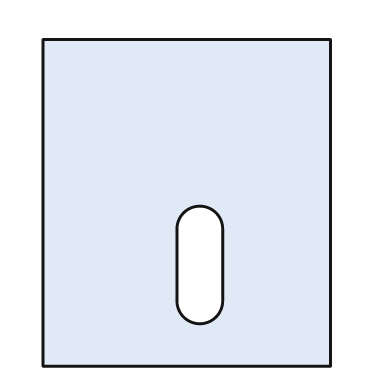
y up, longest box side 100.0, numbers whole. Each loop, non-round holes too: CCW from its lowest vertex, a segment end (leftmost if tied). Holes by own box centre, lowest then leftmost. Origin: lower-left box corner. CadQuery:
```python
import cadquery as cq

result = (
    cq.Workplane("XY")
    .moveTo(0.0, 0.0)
    .lineTo(88.0, 0.0)
    .lineTo(88.0, 100.0)
    .lineTo(0.0, 100.0)
    .close()
    .moveTo(41.0, 20.0)
    .threePointArc((48.0, 13.0), (55.0, 20.0))
    .lineTo(55.0, 42.0)
    .threePointArc((48.0, 49.0), (41.0, 42.0))
    .close()
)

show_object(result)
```